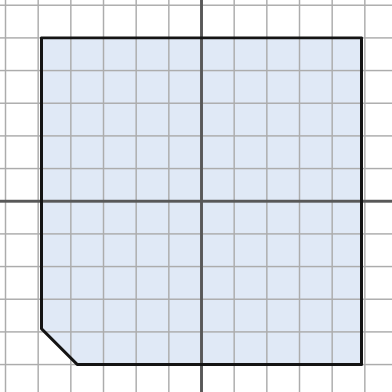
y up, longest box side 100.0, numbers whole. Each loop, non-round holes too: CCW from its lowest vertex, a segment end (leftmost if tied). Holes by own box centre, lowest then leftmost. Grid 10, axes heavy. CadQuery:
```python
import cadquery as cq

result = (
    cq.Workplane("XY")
    .moveTo(-38.0, -50.0)
    .lineTo(49.0, -50.0)
    .lineTo(49.0, 50.0)
    .lineTo(-49.0, 50.0)
    .lineTo(-49.0, -39.0)
    .close()
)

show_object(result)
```